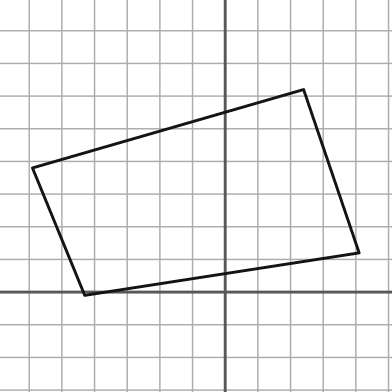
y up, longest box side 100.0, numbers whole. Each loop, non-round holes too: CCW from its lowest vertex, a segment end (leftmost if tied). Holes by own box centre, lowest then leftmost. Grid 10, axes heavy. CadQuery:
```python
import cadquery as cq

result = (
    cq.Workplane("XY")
    .moveTo(-43.0, -1.0)
    .lineTo(41.0, 12.0)
    .lineTo(24.0, 62.0)
    .lineTo(-59.0, 38.0)
    .close()
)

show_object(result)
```